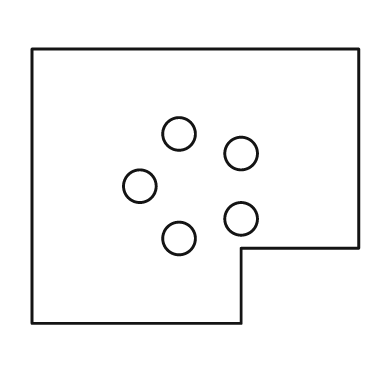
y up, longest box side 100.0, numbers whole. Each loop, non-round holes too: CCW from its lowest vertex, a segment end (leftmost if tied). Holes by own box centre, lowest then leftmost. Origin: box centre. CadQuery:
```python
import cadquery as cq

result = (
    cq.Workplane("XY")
    .moveTo(-50.0, -42.0)
    .lineTo(14.0, -42.0)
    .lineTo(14.0, -19.0)
    .lineTo(50.0, -19.0)
    .lineTo(50.0, 42.0)
    .lineTo(-50.0, 42.0)
    .close()
    .moveTo(-5.0, -16.0)
    .circle(5.0)
    .moveTo(14.0, -10.0)
    .circle(5.0)
    .moveTo(-17.0, 0.0)
    .circle(5.0)
    .moveTo(14.0, 10.0)
    .circle(5.0)
    .moveTo(-5.0, 16.0)
    .circle(5.0)
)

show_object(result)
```